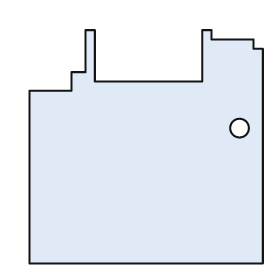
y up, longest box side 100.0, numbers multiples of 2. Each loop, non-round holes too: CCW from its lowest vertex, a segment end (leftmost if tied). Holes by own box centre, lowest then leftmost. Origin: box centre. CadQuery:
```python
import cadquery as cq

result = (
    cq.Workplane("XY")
    .moveTo(-50.0, -50.0)
    .lineTo(50.0, -50.0)
    .lineTo(50.0, 42.0)
    .lineTo(46.0, 42.0)
    .lineTo(46.0, 46.0)
    .lineTo(28.0, 46.0)
    .lineTo(28.0, 50.0)
    .lineTo(24.0, 50.0)
    .lineTo(24.0, 28.0)
    .lineTo(-22.0, 28.0)
    .lineTo(-22.0, 50.0)
    .lineTo(-26.0, 50.0)
    .lineTo(-26.0, 32.0)
    .lineTo(-32.0, 32.0)
    .lineTo(-32.0, 24.0)
    .lineTo(-50.0, 24.0)
    .close()
    .moveTo(40.0, 8.0)
    .circle(4.0)
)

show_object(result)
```